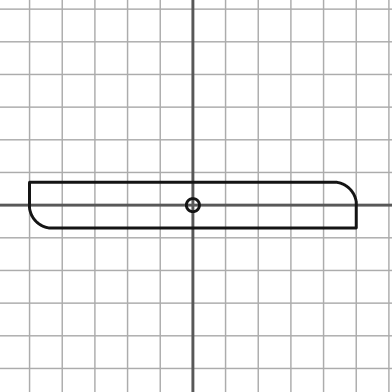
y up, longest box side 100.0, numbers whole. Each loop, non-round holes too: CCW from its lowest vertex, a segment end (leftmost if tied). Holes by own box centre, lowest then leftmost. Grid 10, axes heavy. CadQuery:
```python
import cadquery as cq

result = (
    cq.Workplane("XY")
    .moveTo(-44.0, -7.0)
    .lineTo(50.0, -7.0)
    .lineTo(50.0, 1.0)
    .threePointArc((48.0, 5.0), (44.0, 7.0))
    .lineTo(-50.0, 7.0)
    .lineTo(-50.0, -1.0)
    .threePointArc((-48.0, -5.0), (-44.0, -7.0))
    .close()
    .moveTo(0.0, 0.0)
    .circle(2.0)
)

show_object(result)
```